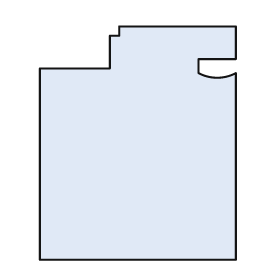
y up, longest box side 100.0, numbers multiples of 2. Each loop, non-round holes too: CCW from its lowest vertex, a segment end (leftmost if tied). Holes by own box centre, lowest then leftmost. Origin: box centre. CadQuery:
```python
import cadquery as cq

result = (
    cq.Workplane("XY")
    .moveTo(-42.0, -50.0)
    .lineTo(42.0, -50.0)
    .lineTo(42.0, 30.0)
    .threePointArc((34.0, 28.0), (26.0, 30.0))
    .lineTo(26.0, 36.0)
    .lineTo(42.0, 36.0)
    .lineTo(42.0, 50.0)
    .lineTo(-8.0, 50.0)
    .lineTo(-8.0, 46.0)
    .lineTo(-12.0, 46.0)
    .lineTo(-12.0, 32.0)
    .lineTo(-42.0, 32.0)
    .close()
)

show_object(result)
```